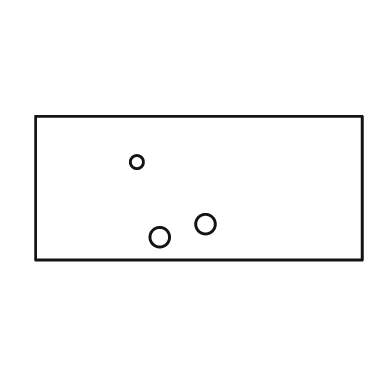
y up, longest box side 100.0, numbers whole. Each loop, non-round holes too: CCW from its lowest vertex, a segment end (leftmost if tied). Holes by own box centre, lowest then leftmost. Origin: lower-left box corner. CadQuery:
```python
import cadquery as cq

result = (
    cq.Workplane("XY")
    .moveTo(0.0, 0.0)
    .lineTo(100.0, 0.0)
    .lineTo(100.0, 44.0)
    .lineTo(0.0, 44.0)
    .close()
    .moveTo(38.0, 7.0)
    .circle(3.0)
    .moveTo(52.0, 11.0)
    .circle(3.0)
    .moveTo(31.0, 30.0)
    .circle(2.0)
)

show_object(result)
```